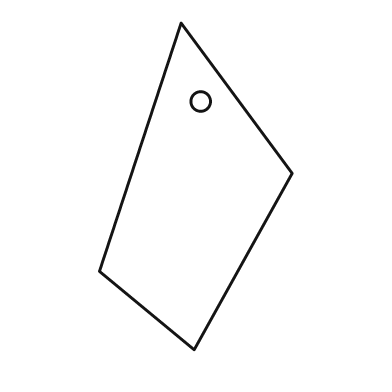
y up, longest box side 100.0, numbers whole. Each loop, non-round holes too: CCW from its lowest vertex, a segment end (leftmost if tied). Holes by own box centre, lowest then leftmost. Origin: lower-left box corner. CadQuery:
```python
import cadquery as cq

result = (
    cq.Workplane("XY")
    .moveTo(29.0, 0.0)
    .lineTo(59.0, 54.0)
    .lineTo(25.0, 100.0)
    .lineTo(0.0, 24.0)
    .close()
    .moveTo(31.0, 76.0)
    .circle(3.0)
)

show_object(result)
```